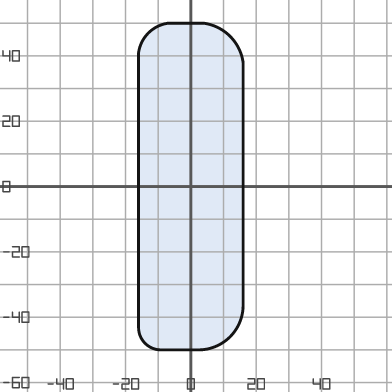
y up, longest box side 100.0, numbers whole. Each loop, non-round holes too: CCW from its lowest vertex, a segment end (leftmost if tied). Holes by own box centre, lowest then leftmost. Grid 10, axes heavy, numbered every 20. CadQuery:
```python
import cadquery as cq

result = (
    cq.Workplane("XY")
    .moveTo(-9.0, -50.0)
    .lineTo(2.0, -50.0)
    .threePointArc((12.0, -46.0), (16.0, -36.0))
    .lineTo(16.0, 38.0)
    .threePointArc((12.0, 46.0), (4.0, 50.0))
    .lineTo(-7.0, 50.0)
    .threePointArc((-13.0, 47.0), (-16.0, 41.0))
    .lineTo(-16.0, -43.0)
    .threePointArc((-14.0, -48.0), (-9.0, -50.0))
    .close()
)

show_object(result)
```